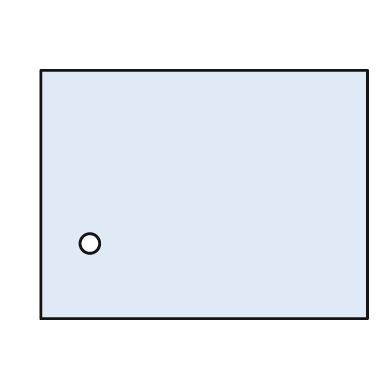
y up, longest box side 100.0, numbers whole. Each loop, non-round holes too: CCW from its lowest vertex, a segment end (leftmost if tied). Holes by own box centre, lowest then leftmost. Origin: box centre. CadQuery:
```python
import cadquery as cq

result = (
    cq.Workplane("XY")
    .moveTo(-50.0, -38.0)
    .lineTo(50.0, -38.0)
    .lineTo(50.0, 38.0)
    .lineTo(-50.0, 38.0)
    .close()
    .moveTo(-35.0, -15.0)
    .circle(3.0)
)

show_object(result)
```